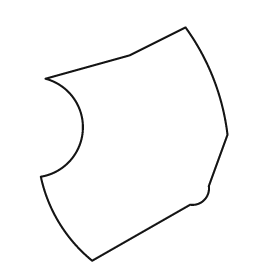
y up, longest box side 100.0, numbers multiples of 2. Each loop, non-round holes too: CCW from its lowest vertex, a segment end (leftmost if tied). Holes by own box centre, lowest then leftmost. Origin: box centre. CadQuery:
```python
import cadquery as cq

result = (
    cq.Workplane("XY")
    .moveTo(-18.0, -50.0)
    .lineTo(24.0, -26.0)
    .threePointArc((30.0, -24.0), (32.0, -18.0))
    .lineTo(40.0, 4.0)
    .threePointArc((34.0, 28.0), (22.0, 50.0))
    .lineTo(-2.0, 38.0)
    .lineTo(-38.0, 28.0)
    .threePointArc((-22.0, 6.0), (-40.0, -14.0))
    .threePointArc((-32.0, -34.0), (-18.0, -50.0))
    .close()
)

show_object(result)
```